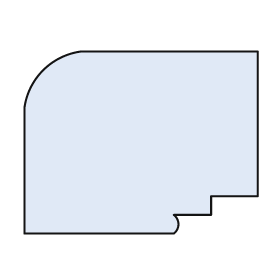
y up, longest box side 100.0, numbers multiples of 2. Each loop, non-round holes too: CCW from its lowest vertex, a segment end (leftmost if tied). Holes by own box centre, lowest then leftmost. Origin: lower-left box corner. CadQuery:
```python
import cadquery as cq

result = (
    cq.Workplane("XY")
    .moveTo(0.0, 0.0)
    .lineTo(64.0, 0.0)
    .threePointArc((66.0, 4.0), (64.0, 8.0))
    .lineTo(80.0, 8.0)
    .lineTo(80.0, 16.0)
    .lineTo(100.0, 16.0)
    .lineTo(100.0, 78.0)
    .lineTo(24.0, 78.0)
    .threePointArc((8.0, 70.0), (0.0, 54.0))
    .close()
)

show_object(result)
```